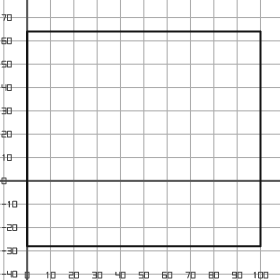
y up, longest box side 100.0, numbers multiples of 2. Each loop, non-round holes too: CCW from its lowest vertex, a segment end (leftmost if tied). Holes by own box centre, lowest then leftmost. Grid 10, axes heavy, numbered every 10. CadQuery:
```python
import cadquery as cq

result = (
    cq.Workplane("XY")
    .moveTo(0.0, -28.0)
    .lineTo(100.0, -28.0)
    .lineTo(100.0, 64.0)
    .lineTo(0.0, 64.0)
    .close()
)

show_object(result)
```